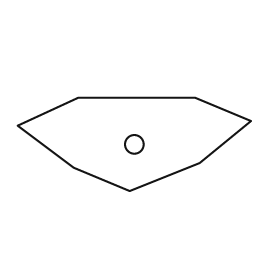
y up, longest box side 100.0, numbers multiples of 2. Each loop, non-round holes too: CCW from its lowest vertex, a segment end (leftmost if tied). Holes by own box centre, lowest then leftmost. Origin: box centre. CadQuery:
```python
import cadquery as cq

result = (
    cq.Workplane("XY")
    .moveTo(-2.0, -20.0)
    .lineTo(28.0, -8.0)
    .lineTo(50.0, 10.0)
    .lineTo(26.0, 20.0)
    .lineTo(-24.0, 20.0)
    .lineTo(-50.0, 8.0)
    .lineTo(-26.0, -10.0)
    .close()
    .moveTo(0.0, 0.0)
    .circle(4.0)
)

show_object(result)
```